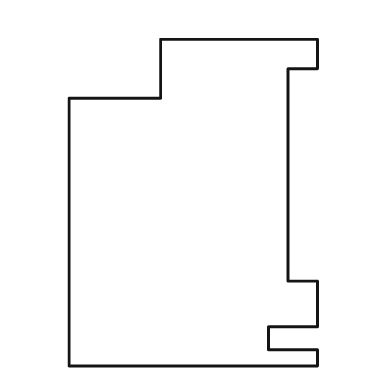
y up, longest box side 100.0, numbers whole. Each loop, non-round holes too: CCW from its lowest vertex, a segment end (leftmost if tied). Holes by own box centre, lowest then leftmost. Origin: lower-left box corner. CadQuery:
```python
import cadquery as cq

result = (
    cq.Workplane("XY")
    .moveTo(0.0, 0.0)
    .lineTo(76.0, 0.0)
    .lineTo(76.0, 5.0)
    .lineTo(61.0, 5.0)
    .lineTo(61.0, 12.0)
    .lineTo(76.0, 12.0)
    .lineTo(76.0, 26.0)
    .lineTo(67.0, 26.0)
    .lineTo(67.0, 91.0)
    .lineTo(76.0, 91.0)
    .lineTo(76.0, 100.0)
    .lineTo(28.0, 100.0)
    .lineTo(28.0, 82.0)
    .lineTo(0.0, 82.0)
    .close()
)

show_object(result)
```